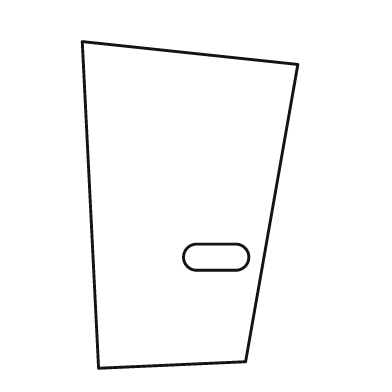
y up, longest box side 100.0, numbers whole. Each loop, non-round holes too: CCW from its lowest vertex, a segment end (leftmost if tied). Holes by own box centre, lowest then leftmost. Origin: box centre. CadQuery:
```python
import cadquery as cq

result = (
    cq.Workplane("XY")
    .moveTo(-28.0, -50.0)
    .lineTo(17.0, -48.0)
    .lineTo(33.0, 43.0)
    .lineTo(-33.0, 50.0)
    .close()
    .moveTo(2.0, -20.0)
    .lineTo(14.0, -20.0)
    .threePointArc((18.0, -16.0), (14.0, -12.0))
    .lineTo(2.0, -12.0)
    .threePointArc((-2.0, -16.0), (2.0, -20.0))
    .close()
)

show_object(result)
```